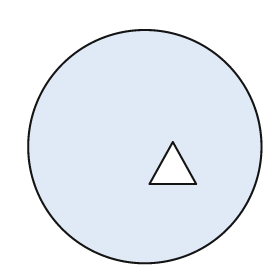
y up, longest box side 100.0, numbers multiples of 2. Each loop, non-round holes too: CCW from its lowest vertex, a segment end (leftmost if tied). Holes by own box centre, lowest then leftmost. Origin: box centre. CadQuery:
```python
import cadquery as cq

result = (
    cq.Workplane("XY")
    .moveTo(0.0, 0.0)
    .circle(50.0)
    .moveTo(2.0, -16.0)
    .lineTo(22.0, -16.0)
    .lineTo(12.0, 2.0)
    .close()
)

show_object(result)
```